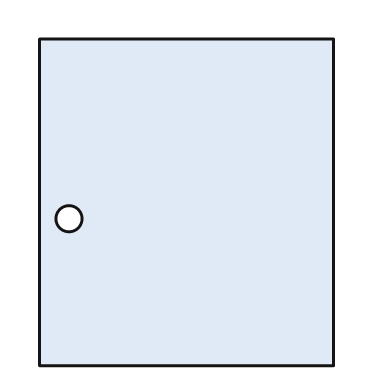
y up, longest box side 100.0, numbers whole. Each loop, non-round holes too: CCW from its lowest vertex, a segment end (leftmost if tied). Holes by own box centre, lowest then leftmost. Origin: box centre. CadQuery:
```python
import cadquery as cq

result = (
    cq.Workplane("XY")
    .moveTo(-45.0, -50.0)
    .lineTo(45.0, -50.0)
    .lineTo(45.0, 50.0)
    .lineTo(-45.0, 50.0)
    .close()
    .moveTo(-36.0, -5.0)
    .circle(4.0)
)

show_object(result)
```